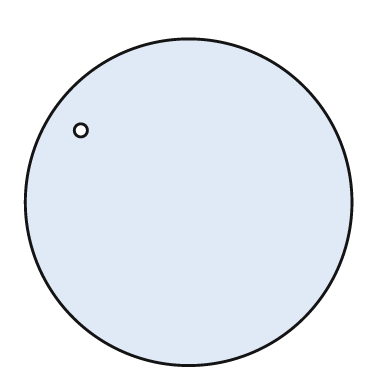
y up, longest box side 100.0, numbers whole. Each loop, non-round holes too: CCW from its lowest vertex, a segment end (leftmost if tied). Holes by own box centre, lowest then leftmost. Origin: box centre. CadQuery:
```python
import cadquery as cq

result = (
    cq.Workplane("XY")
    .moveTo(0.0, 0.0)
    .circle(50.0)
    .moveTo(-33.0, 22.0)
    .circle(2.0)
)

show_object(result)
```